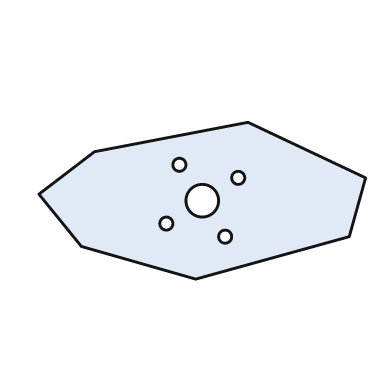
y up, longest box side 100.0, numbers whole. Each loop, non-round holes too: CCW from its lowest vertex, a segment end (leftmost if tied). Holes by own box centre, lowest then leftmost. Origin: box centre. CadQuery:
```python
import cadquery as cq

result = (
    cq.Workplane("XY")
    .moveTo(-2.0, -24.0)
    .lineTo(45.0, -11.0)
    .lineTo(50.0, 7.0)
    .lineTo(14.0, 24.0)
    .lineTo(-33.0, 15.0)
    .lineTo(-50.0, 2.0)
    .lineTo(-37.0, -14.0)
    .close()
    .moveTo(7.0, -11.0)
    .circle(2.0)
    .moveTo(-11.0, -7.0)
    .circle(2.0)
    .moveTo(0.0, 0.0)
    .circle(5.0)
    .moveTo(11.0, 7.0)
    .circle(2.0)
    .moveTo(-7.0, 11.0)
    .circle(2.0)
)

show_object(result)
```